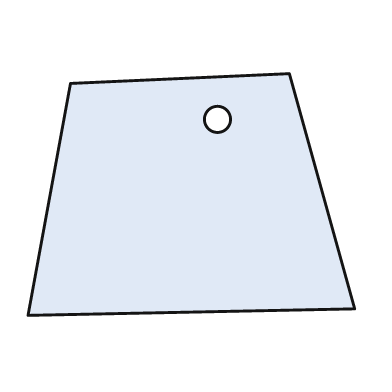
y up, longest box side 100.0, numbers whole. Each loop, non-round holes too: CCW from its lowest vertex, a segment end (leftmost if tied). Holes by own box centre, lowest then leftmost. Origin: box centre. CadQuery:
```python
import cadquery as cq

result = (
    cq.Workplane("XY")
    .moveTo(-50.0, -37.0)
    .lineTo(50.0, -35.0)
    .lineTo(30.0, 37.0)
    .lineTo(-37.0, 34.0)
    .close()
    .moveTo(8.0, 23.0)
    .circle(4.0)
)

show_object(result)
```